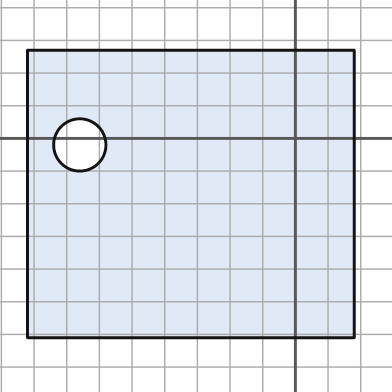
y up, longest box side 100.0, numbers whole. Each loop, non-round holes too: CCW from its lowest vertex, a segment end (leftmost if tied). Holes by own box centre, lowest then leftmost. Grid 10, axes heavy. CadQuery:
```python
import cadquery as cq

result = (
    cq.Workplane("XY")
    .moveTo(-82.0, -61.0)
    .lineTo(18.0, -61.0)
    .lineTo(18.0, 27.0)
    .lineTo(-82.0, 27.0)
    .close()
    .moveTo(-66.0, -2.0)
    .circle(8.0)
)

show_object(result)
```